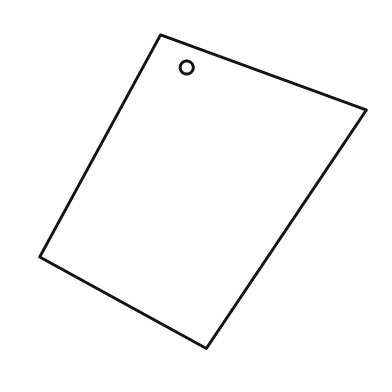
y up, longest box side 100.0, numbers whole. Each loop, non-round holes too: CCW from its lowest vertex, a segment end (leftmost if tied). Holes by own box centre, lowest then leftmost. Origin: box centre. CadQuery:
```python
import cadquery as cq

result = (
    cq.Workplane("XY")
    .moveTo(1.0, -48.0)
    .lineTo(50.0, 25.0)
    .lineTo(-13.0, 48.0)
    .lineTo(-50.0, -20.0)
    .close()
    .moveTo(-5.0, 38.0)
    .circle(2.0)
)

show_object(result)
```